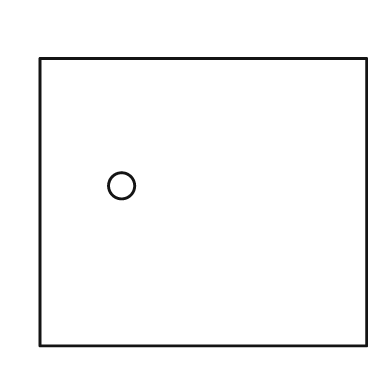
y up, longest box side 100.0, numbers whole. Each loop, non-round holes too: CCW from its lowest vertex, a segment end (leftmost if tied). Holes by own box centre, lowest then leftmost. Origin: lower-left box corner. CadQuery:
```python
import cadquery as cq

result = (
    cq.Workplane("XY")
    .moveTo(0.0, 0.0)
    .lineTo(100.0, 0.0)
    .lineTo(100.0, 88.0)
    .lineTo(0.0, 88.0)
    .close()
    .moveTo(25.0, 49.0)
    .circle(4.0)
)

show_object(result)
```